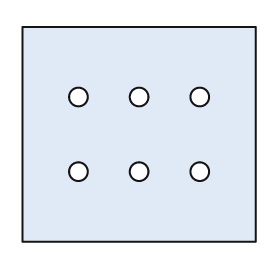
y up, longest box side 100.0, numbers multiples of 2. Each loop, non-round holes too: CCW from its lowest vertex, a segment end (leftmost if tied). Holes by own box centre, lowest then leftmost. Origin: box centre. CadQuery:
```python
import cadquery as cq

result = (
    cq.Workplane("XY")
    .moveTo(-50.0, -46.0)
    .lineTo(50.0, -46.0)
    .lineTo(50.0, 46.0)
    .lineTo(-50.0, 46.0)
    .close()
    .moveTo(-26.0, -16.0)
    .circle(4.0)
    .moveTo(0.0, -16.0)
    .circle(4.0)
    .moveTo(26.0, -16.0)
    .circle(4.0)
    .moveTo(-26.0, 16.0)
    .circle(4.0)
    .moveTo(0.0, 16.0)
    .circle(4.0)
    .moveTo(26.0, 16.0)
    .circle(4.0)
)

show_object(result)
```